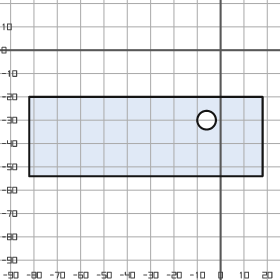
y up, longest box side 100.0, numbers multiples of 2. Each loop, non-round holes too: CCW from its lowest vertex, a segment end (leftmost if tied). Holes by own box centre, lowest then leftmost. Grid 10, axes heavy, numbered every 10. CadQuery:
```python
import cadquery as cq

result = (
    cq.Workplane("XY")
    .moveTo(-82.0, -54.0)
    .lineTo(18.0, -54.0)
    .lineTo(18.0, -20.0)
    .lineTo(-82.0, -20.0)
    .close()
    .moveTo(-6.0, -30.0)
    .circle(4.0)
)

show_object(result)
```